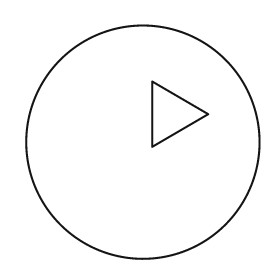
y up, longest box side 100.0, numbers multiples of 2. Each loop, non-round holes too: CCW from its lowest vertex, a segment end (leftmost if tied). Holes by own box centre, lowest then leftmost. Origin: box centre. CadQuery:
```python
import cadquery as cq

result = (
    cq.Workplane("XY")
    .moveTo(0.0, 0.0)
    .circle(50.0)
    .moveTo(4.0, -2.0)
    .lineTo(28.0, 12.0)
    .lineTo(4.0, 26.0)
    .close()
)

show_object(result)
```